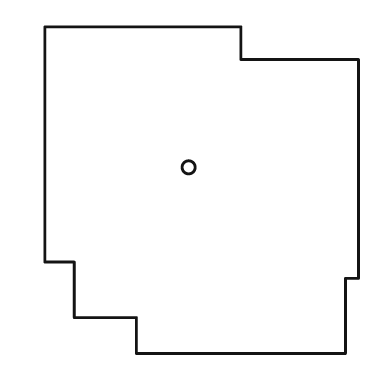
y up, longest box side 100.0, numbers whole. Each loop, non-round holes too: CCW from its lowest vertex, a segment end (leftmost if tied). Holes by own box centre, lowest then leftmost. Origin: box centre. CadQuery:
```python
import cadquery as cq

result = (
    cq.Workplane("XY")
    .moveTo(-20.0, -50.0)
    .lineTo(44.0, -50.0)
    .lineTo(44.0, -27.0)
    .lineTo(48.0, -27.0)
    .lineTo(48.0, 40.0)
    .lineTo(12.0, 40.0)
    .lineTo(12.0, 50.0)
    .lineTo(-48.0, 50.0)
    .lineTo(-48.0, -22.0)
    .lineTo(-39.0, -22.0)
    .lineTo(-39.0, -39.0)
    .lineTo(-20.0, -39.0)
    .close()
    .moveTo(-4.0, 7.0)
    .circle(2.0)
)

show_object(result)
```